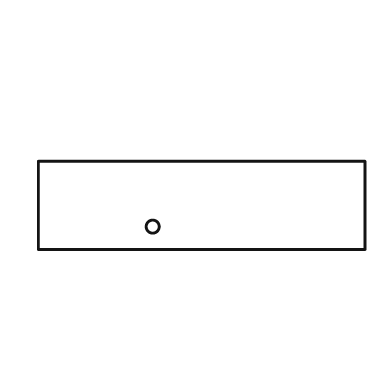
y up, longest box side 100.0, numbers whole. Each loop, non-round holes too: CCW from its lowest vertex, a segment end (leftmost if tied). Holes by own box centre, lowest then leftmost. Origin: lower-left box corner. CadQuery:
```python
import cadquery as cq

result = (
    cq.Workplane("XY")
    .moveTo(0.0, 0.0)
    .lineTo(100.0, 0.0)
    .lineTo(100.0, 27.0)
    .lineTo(0.0, 27.0)
    .close()
    .moveTo(35.0, 7.0)
    .circle(2.0)
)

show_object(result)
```